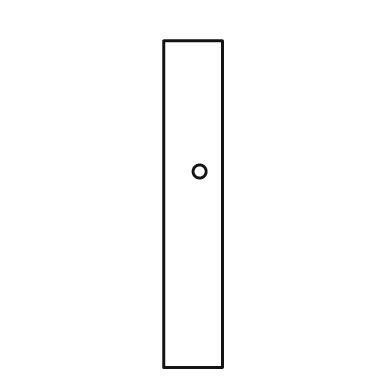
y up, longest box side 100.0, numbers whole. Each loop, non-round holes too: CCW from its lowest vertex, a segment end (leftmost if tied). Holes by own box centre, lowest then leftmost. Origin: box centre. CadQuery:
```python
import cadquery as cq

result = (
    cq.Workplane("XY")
    .moveTo(-9.0, -50.0)
    .lineTo(9.0, -50.0)
    .lineTo(9.0, 50.0)
    .lineTo(-9.0, 50.0)
    .close()
    .moveTo(2.0, 10.0)
    .circle(2.0)
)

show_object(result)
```